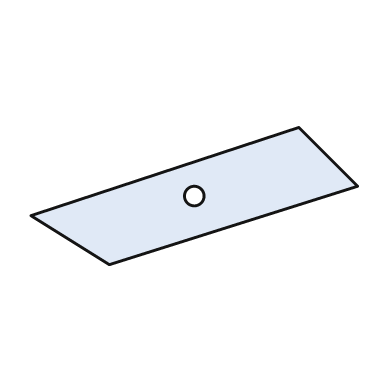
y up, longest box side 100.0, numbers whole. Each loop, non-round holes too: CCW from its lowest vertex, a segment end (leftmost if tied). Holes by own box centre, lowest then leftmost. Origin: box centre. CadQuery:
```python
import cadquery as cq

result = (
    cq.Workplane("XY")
    .moveTo(-26.0, -21.0)
    .lineTo(50.0, 3.0)
    .lineTo(32.0, 21.0)
    .lineTo(-50.0, -6.0)
    .close()
    .moveTo(0.0, 0.0)
    .circle(3.0)
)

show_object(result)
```